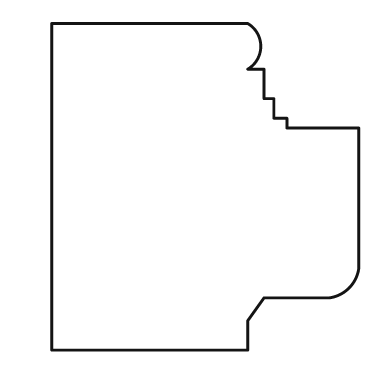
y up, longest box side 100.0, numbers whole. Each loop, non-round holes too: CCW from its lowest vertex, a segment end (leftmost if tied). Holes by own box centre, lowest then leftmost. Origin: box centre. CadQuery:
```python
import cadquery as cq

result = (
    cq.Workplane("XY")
    .moveTo(-47.0, -50.0)
    .lineTo(13.0, -50.0)
    .lineTo(13.0, -41.0)
    .lineTo(18.0, -34.0)
    .lineTo(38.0, -34.0)
    .threePointArc((44.0, -31.0), (47.0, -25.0))
    .lineTo(47.0, 18.0)
    .lineTo(25.0, 18.0)
    .lineTo(25.0, 21.0)
    .lineTo(21.0, 21.0)
    .lineTo(21.0, 27.0)
    .lineTo(18.0, 27.0)
    .lineTo(18.0, 36.0)
    .lineTo(13.0, 36.0)
    .threePointArc((17.0, 43.0), (13.0, 50.0))
    .lineTo(-47.0, 50.0)
    .close()
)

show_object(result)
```